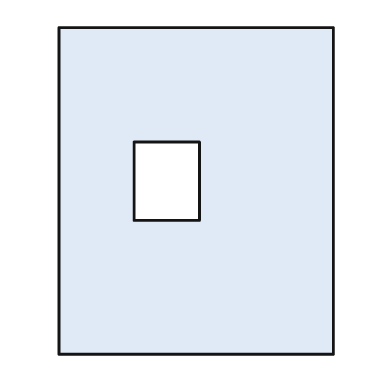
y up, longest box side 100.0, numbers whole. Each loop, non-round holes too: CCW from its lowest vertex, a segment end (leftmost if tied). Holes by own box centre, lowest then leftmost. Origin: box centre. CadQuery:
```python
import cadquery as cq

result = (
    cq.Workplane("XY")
    .moveTo(-42.0, -50.0)
    .lineTo(42.0, -50.0)
    .lineTo(42.0, 50.0)
    .lineTo(-42.0, 50.0)
    .close()
    .moveTo(-19.0, -9.0)
    .lineTo(1.0, -9.0)
    .lineTo(1.0, 15.0)
    .lineTo(-19.0, 15.0)
    .close()
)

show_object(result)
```